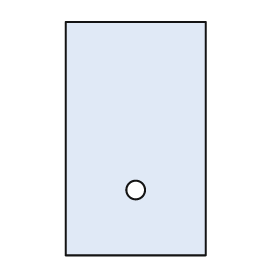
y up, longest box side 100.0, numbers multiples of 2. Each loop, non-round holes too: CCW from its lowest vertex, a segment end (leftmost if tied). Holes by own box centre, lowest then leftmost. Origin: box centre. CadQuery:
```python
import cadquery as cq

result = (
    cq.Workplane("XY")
    .moveTo(-30.0, -50.0)
    .lineTo(30.0, -50.0)
    .lineTo(30.0, 50.0)
    .lineTo(-30.0, 50.0)
    .close()
    .moveTo(0.0, -22.0)
    .circle(4.0)
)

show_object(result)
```